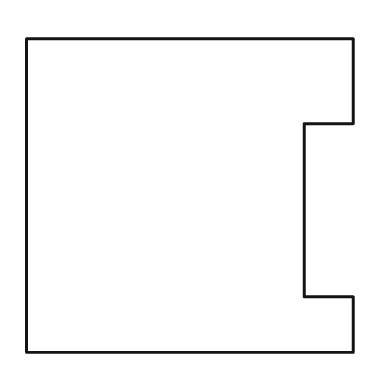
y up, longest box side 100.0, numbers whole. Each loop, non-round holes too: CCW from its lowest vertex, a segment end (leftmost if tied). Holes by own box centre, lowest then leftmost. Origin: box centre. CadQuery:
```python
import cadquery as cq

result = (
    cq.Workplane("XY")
    .moveTo(-50.0, -48.0)
    .lineTo(50.0, -48.0)
    .lineTo(50.0, -31.0)
    .lineTo(35.0, -31.0)
    .lineTo(35.0, 22.0)
    .lineTo(50.0, 22.0)
    .lineTo(50.0, 48.0)
    .lineTo(-50.0, 48.0)
    .close()
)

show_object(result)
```